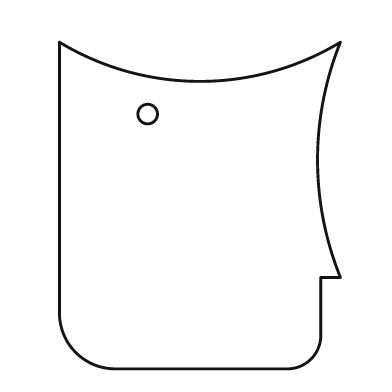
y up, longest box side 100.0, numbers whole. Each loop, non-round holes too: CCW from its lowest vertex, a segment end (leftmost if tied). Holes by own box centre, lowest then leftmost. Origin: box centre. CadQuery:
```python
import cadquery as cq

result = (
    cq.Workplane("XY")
    .moveTo(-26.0, -50.0)
    .lineTo(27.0, -50.0)
    .threePointArc((34.0, -47.0), (37.0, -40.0))
    .lineTo(37.0, -22.0)
    .lineTo(43.0, -22.0)
    .threePointArc((36.0, 14.0), (43.0, 50.0))
    .threePointArc((0.0, 38.0), (-43.0, 50.0))
    .lineTo(-43.0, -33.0)
    .threePointArc((-38.0, -45.0), (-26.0, -50.0))
    .close()
    .moveTo(-16.0, 28.0)
    .circle(3.0)
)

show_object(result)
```